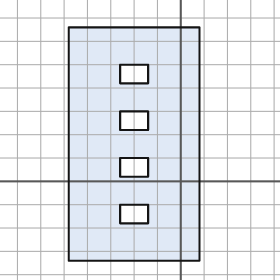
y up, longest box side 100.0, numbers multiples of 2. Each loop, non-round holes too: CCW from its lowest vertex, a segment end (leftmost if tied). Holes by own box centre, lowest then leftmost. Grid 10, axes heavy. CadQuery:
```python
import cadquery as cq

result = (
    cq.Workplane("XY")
    .moveTo(-48.0, -34.0)
    .lineTo(8.0, -34.0)
    .lineTo(8.0, 66.0)
    .lineTo(-48.0, 66.0)
    .close()
    .moveTo(-26.0, -18.0)
    .lineTo(-14.0, -18.0)
    .lineTo(-14.0, -10.0)
    .lineTo(-26.0, -10.0)
    .close()
    .moveTo(-26.0, 2.0)
    .lineTo(-14.0, 2.0)
    .lineTo(-14.0, 10.0)
    .lineTo(-26.0, 10.0)
    .close()
    .moveTo(-26.0, 22.0)
    .lineTo(-14.0, 22.0)
    .lineTo(-14.0, 30.0)
    .lineTo(-26.0, 30.0)
    .close()
    .moveTo(-26.0, 42.0)
    .lineTo(-14.0, 42.0)
    .lineTo(-14.0, 50.0)
    .lineTo(-26.0, 50.0)
    .close()
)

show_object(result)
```